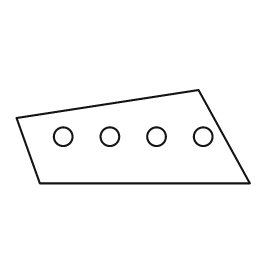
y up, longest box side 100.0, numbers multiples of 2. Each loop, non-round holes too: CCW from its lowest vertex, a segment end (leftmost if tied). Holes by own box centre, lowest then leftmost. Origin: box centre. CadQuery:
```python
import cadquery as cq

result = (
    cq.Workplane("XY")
    .moveTo(-40.0, -20.0)
    .lineTo(50.0, -20.0)
    .lineTo(28.0, 20.0)
    .lineTo(-50.0, 8.0)
    .close()
    .moveTo(-30.0, 0.0)
    .circle(4.0)
    .moveTo(-10.0, 0.0)
    .circle(4.0)
    .moveTo(10.0, 0.0)
    .circle(4.0)
    .moveTo(30.0, 0.0)
    .circle(4.0)
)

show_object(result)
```